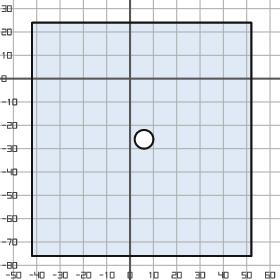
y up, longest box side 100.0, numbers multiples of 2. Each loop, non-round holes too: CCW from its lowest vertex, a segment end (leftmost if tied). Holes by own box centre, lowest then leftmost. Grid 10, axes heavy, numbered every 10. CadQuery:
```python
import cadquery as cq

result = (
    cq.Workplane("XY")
    .moveTo(-42.0, -76.0)
    .lineTo(52.0, -76.0)
    .lineTo(52.0, 24.0)
    .lineTo(-42.0, 24.0)
    .close()
    .moveTo(6.0, -26.0)
    .circle(4.0)
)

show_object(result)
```